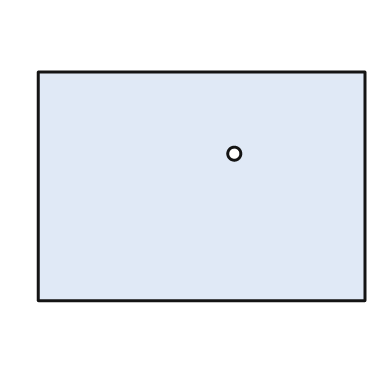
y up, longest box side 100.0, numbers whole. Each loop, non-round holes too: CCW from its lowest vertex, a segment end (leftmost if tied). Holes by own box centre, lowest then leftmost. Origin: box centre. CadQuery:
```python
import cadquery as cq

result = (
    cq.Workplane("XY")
    .moveTo(-50.0, -35.0)
    .lineTo(50.0, -35.0)
    .lineTo(50.0, 35.0)
    .lineTo(-50.0, 35.0)
    .close()
    .moveTo(10.0, 10.0)
    .circle(2.0)
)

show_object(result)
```